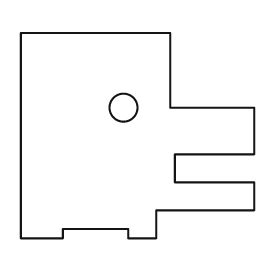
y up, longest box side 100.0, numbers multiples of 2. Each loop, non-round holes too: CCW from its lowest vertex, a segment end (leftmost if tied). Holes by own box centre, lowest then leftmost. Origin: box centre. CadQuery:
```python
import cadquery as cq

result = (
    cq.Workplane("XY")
    .moveTo(-50.0, -44.0)
    .lineTo(-32.0, -44.0)
    .lineTo(-32.0, -40.0)
    .lineTo(-4.0, -40.0)
    .lineTo(-4.0, -44.0)
    .lineTo(8.0, -44.0)
    .lineTo(8.0, -32.0)
    .lineTo(50.0, -32.0)
    .lineTo(50.0, -20.0)
    .lineTo(16.0, -20.0)
    .lineTo(16.0, -8.0)
    .lineTo(50.0, -8.0)
    .lineTo(50.0, 12.0)
    .lineTo(14.0, 12.0)
    .lineTo(14.0, 44.0)
    .lineTo(-50.0, 44.0)
    .close()
    .moveTo(-6.0, 12.0)
    .circle(6.0)
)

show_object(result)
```